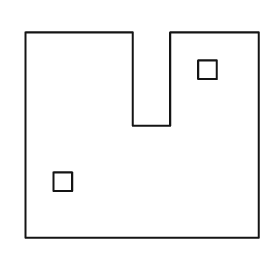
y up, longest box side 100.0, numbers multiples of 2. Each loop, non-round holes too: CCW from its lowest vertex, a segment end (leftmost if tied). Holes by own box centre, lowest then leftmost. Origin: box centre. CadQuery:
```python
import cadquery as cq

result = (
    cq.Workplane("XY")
    .moveTo(-50.0, -44.0)
    .lineTo(50.0, -44.0)
    .lineTo(50.0, 44.0)
    .lineTo(12.0, 44.0)
    .lineTo(12.0, 4.0)
    .lineTo(-4.0, 4.0)
    .lineTo(-4.0, 44.0)
    .lineTo(-50.0, 44.0)
    .close()
    .moveTo(-38.0, -24.0)
    .lineTo(-30.0, -24.0)
    .lineTo(-30.0, -16.0)
    .lineTo(-38.0, -16.0)
    .close()
    .moveTo(24.0, 24.0)
    .lineTo(32.0, 24.0)
    .lineTo(32.0, 32.0)
    .lineTo(24.0, 32.0)
    .close()
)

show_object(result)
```